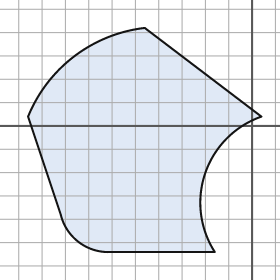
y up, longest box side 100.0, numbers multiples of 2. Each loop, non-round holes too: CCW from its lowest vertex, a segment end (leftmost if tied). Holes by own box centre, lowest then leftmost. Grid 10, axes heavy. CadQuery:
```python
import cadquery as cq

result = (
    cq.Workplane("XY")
    .moveTo(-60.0, -54.0)
    .lineTo(-16.0, -54.0)
    .threePointArc((-20.0, -20.0), (4.0, 4.0))
    .lineTo(-46.0, 42.0)
    .threePointArc((-76.0, 30.0), (-96.0, 4.0))
    .lineTo(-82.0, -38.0)
    .threePointArc((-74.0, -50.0), (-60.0, -54.0))
    .close()
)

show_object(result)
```